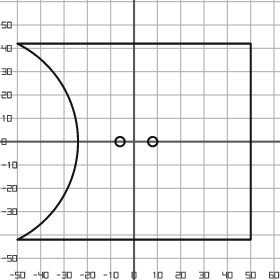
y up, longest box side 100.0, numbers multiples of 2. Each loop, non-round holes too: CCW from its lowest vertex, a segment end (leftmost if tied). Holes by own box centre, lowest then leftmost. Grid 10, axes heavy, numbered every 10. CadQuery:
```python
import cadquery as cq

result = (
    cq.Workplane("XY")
    .moveTo(-50.0, -42.0)
    .lineTo(50.0, -42.0)
    .lineTo(50.0, 42.0)
    .lineTo(-50.0, 42.0)
    .threePointArc((-24.0, 0.0), (-50.0, -42.0))
    .close()
    .moveTo(-6.0, 0.0)
    .circle(2.0)
    .moveTo(8.0, 0.0)
    .circle(2.0)
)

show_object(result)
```